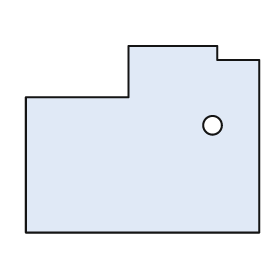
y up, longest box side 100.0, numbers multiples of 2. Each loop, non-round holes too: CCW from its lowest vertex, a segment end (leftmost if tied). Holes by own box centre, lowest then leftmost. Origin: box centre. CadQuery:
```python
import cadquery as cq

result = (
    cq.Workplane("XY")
    .moveTo(-50.0, -40.0)
    .lineTo(50.0, -40.0)
    .lineTo(50.0, 34.0)
    .lineTo(32.0, 34.0)
    .lineTo(32.0, 40.0)
    .lineTo(-6.0, 40.0)
    .lineTo(-6.0, 18.0)
    .lineTo(-50.0, 18.0)
    .close()
    .moveTo(30.0, 6.0)
    .circle(4.0)
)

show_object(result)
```